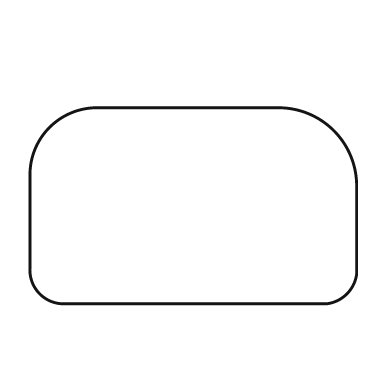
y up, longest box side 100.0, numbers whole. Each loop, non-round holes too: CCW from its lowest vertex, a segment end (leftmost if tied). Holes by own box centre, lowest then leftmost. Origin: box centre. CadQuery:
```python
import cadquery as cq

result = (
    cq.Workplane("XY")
    .moveTo(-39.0, -30.0)
    .lineTo(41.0, -30.0)
    .threePointArc((47.0, -27.0), (50.0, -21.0))
    .lineTo(50.0, 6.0)
    .threePointArc((43.0, 23.0), (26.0, 30.0))
    .lineTo(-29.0, 30.0)
    .threePointArc((-44.0, 24.0), (-50.0, 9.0))
    .lineTo(-50.0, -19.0)
    .threePointArc((-47.0, -27.0), (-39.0, -30.0))
    .close()
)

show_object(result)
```